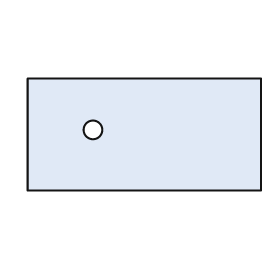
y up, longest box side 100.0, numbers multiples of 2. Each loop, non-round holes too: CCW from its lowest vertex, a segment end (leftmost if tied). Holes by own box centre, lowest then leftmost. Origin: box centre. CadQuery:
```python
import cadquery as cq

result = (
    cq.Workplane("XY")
    .moveTo(-50.0, -24.0)
    .lineTo(50.0, -24.0)
    .lineTo(50.0, 24.0)
    .lineTo(-50.0, 24.0)
    .close()
    .moveTo(-22.0, 2.0)
    .circle(4.0)
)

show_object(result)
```